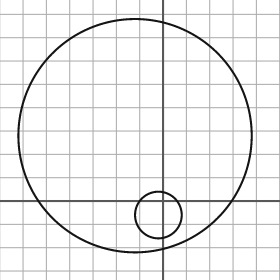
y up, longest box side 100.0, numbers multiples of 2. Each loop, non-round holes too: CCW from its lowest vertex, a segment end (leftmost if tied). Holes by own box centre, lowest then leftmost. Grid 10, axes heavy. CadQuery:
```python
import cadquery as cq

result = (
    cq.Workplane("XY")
    .moveTo(-12.0, 28.0)
    .circle(50.0)
    .moveTo(-2.0, -6.0)
    .circle(10.0)
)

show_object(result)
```